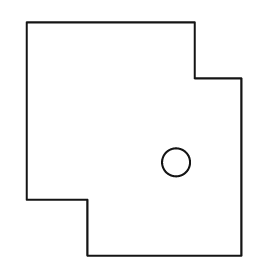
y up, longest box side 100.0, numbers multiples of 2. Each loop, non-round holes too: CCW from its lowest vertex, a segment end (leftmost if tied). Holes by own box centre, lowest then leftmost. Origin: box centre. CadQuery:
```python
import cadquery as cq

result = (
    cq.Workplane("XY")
    .moveTo(-20.0, -50.0)
    .lineTo(46.0, -50.0)
    .lineTo(46.0, 26.0)
    .lineTo(26.0, 26.0)
    .lineTo(26.0, 50.0)
    .lineTo(-46.0, 50.0)
    .lineTo(-46.0, -26.0)
    .lineTo(-20.0, -26.0)
    .close()
    .moveTo(18.0, -10.0)
    .circle(6.0)
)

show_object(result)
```